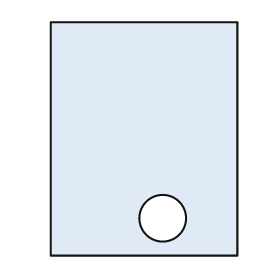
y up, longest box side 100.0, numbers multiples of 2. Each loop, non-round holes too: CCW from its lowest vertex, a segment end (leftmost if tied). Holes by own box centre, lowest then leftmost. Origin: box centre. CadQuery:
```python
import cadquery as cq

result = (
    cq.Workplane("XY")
    .moveTo(-40.0, -50.0)
    .lineTo(40.0, -50.0)
    .lineTo(40.0, 50.0)
    .lineTo(-40.0, 50.0)
    .close()
    .moveTo(8.0, -34.0)
    .circle(10.0)
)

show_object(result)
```